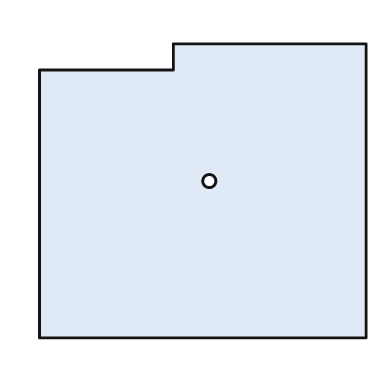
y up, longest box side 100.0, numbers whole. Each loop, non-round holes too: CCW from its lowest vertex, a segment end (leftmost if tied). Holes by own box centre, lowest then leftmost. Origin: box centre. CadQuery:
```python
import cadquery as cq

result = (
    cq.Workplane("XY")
    .moveTo(-50.0, -45.0)
    .lineTo(50.0, -45.0)
    .lineTo(50.0, 45.0)
    .lineTo(-9.0, 45.0)
    .lineTo(-9.0, 37.0)
    .lineTo(-50.0, 37.0)
    .close()
    .moveTo(2.0, 3.0)
    .circle(2.0)
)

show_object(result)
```